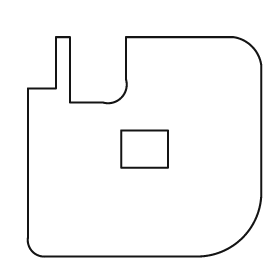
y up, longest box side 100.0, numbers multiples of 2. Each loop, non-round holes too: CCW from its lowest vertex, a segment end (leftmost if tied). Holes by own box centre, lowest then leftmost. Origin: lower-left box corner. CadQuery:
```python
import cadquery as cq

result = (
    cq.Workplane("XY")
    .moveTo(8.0, 0.0)
    .lineTo(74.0, 0.0)
    .threePointArc((92.0, 8.0), (100.0, 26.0))
    .lineTo(100.0, 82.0)
    .threePointArc((96.0, 90.0), (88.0, 94.0))
    .lineTo(42.0, 94.0)
    .lineTo(42.0, 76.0)
    .threePointArc((40.0, 68.0), (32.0, 66.0))
    .lineTo(18.0, 66.0)
    .lineTo(18.0, 94.0)
    .lineTo(12.0, 94.0)
    .lineTo(12.0, 72.0)
    .lineTo(0.0, 72.0)
    .lineTo(0.0, 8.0)
    .threePointArc((2.0, 2.0), (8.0, 0.0))
    .close()
    .moveTo(40.0, 38.0)
    .lineTo(60.0, 38.0)
    .lineTo(60.0, 54.0)
    .lineTo(40.0, 54.0)
    .close()
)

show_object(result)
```